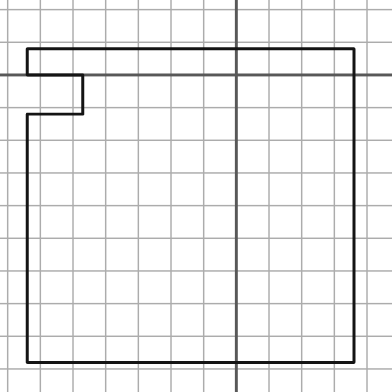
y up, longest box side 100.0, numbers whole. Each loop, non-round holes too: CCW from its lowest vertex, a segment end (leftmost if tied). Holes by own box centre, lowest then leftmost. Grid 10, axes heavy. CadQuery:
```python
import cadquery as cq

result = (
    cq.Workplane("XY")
    .moveTo(-64.0, -88.0)
    .lineTo(36.0, -88.0)
    .lineTo(36.0, 8.0)
    .lineTo(-64.0, 8.0)
    .lineTo(-64.0, 0.0)
    .lineTo(-47.0, 0.0)
    .lineTo(-47.0, -12.0)
    .lineTo(-64.0, -12.0)
    .close()
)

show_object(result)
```